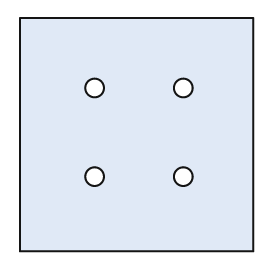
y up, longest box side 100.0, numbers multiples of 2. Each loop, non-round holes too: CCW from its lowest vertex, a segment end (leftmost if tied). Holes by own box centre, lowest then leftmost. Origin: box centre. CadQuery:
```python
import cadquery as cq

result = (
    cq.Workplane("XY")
    .moveTo(-50.0, -50.0)
    .lineTo(50.0, -50.0)
    .lineTo(50.0, 50.0)
    .lineTo(-50.0, 50.0)
    .close()
    .moveTo(-18.0, -18.0)
    .circle(4.0)
    .moveTo(20.0, -18.0)
    .circle(4.0)
    .moveTo(-18.0, 20.0)
    .circle(4.0)
    .moveTo(20.0, 20.0)
    .circle(4.0)
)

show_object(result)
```